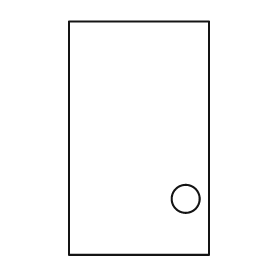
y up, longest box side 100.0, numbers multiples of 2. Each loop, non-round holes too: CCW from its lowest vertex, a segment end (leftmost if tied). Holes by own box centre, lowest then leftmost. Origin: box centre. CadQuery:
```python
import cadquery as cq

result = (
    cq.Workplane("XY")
    .moveTo(-30.0, -50.0)
    .lineTo(30.0, -50.0)
    .lineTo(30.0, 50.0)
    .lineTo(-30.0, 50.0)
    .close()
    .moveTo(20.0, -26.0)
    .circle(6.0)
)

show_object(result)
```